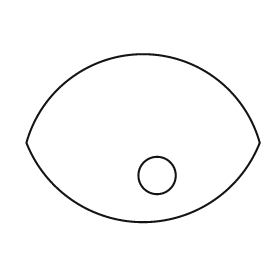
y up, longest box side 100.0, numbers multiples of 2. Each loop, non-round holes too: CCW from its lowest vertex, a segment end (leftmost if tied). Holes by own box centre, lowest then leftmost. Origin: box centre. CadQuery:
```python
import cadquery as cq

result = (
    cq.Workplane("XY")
    .moveTo(-50.0, -2.0)
    .threePointArc((0.0, -36.0), (50.0, -2.0))
    .threePointArc((0.0, 36.0), (-50.0, -2.0))
    .close()
    .moveTo(6.0, -16.0)
    .circle(8.0)
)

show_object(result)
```